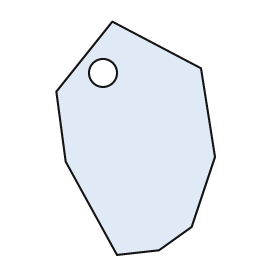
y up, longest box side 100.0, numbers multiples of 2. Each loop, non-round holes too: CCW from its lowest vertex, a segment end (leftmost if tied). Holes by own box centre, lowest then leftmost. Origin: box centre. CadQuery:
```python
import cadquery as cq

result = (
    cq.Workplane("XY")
    .moveTo(-8.0, -50.0)
    .lineTo(10.0, -48.0)
    .lineTo(24.0, -38.0)
    .lineTo(34.0, -8.0)
    .lineTo(28.0, 30.0)
    .lineTo(-10.0, 50.0)
    .lineTo(-34.0, 20.0)
    .lineTo(-30.0, -10.0)
    .close()
    .moveTo(-14.0, 28.0)
    .circle(6.0)
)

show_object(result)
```